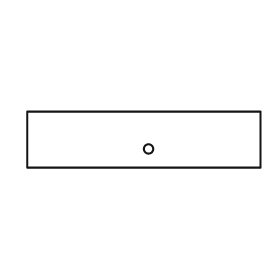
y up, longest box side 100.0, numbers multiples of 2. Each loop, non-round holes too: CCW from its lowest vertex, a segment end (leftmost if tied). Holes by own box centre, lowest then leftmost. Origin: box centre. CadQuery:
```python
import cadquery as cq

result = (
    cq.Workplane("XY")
    .moveTo(-50.0, -12.0)
    .lineTo(50.0, -12.0)
    .lineTo(50.0, 12.0)
    .lineTo(-50.0, 12.0)
    .close()
    .moveTo(2.0, -4.0)
    .circle(2.0)
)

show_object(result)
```